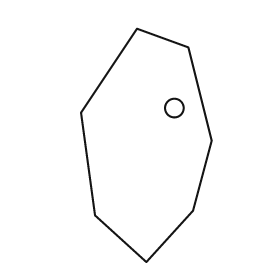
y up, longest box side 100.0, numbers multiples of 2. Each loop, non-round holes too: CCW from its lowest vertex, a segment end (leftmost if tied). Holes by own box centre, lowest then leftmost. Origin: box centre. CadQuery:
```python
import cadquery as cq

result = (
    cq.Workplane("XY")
    .moveTo(0.0, -50.0)
    .lineTo(20.0, -28.0)
    .lineTo(28.0, 2.0)
    .lineTo(18.0, 42.0)
    .lineTo(-4.0, 50.0)
    .lineTo(-28.0, 14.0)
    .lineTo(-22.0, -30.0)
    .close()
    .moveTo(12.0, 16.0)
    .circle(4.0)
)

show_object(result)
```